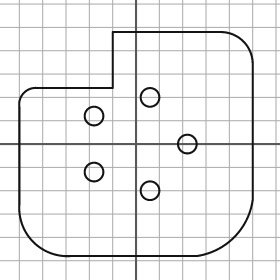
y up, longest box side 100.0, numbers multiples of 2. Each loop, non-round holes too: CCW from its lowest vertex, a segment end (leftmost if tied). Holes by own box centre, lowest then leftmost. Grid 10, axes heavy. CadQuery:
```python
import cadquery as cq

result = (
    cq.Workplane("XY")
    .moveTo(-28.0, -48.0)
    .lineTo(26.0, -48.0)
    .threePointArc((42.0, -40.0), (50.0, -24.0))
    .lineTo(50.0, 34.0)
    .threePointArc((46.0, 44.0), (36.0, 48.0))
    .lineTo(-10.0, 48.0)
    .lineTo(-10.0, 24.0)
    .lineTo(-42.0, 24.0)
    .threePointArc((-48.0, 22.0), (-50.0, 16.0))
    .lineTo(-50.0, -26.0)
    .threePointArc((-44.0, -42.0), (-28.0, -48.0))
    .close()
    .moveTo(6.0, -20.0)
    .circle(4.0)
    .moveTo(-18.0, -12.0)
    .circle(4.0)
    .moveTo(22.0, 0.0)
    .circle(4.0)
    .moveTo(-18.0, 12.0)
    .circle(4.0)
    .moveTo(6.0, 20.0)
    .circle(4.0)
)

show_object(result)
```